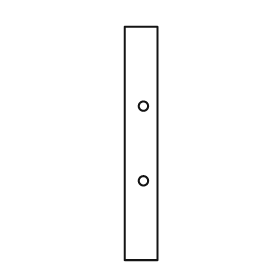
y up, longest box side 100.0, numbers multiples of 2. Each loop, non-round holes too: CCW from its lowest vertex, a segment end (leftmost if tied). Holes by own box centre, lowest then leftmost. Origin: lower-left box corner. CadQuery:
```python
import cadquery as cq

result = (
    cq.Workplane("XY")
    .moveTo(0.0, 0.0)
    .lineTo(14.0, 0.0)
    .lineTo(14.0, 100.0)
    .lineTo(0.0, 100.0)
    .close()
    .moveTo(8.0, 34.0)
    .circle(2.0)
    .moveTo(8.0, 66.0)
    .circle(2.0)
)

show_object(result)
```